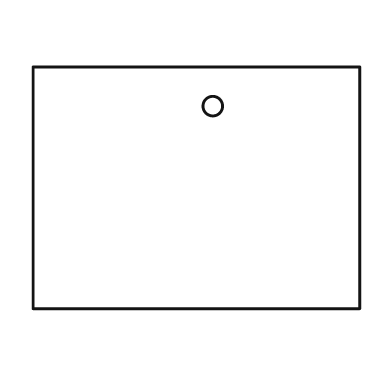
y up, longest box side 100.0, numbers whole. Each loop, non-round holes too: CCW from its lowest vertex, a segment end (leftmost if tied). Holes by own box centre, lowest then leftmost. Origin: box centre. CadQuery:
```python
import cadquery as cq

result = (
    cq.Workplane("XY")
    .moveTo(-50.0, -37.0)
    .lineTo(50.0, -37.0)
    .lineTo(50.0, 37.0)
    .lineTo(-50.0, 37.0)
    .close()
    .moveTo(5.0, 25.0)
    .circle(3.0)
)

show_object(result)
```